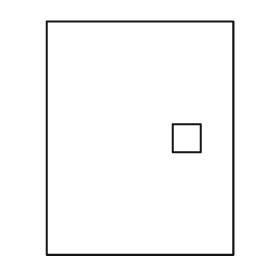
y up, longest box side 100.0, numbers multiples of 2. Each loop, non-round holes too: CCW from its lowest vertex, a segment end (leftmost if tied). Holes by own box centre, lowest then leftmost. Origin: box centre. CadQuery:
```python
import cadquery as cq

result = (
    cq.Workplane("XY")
    .moveTo(-40.0, -50.0)
    .lineTo(40.0, -50.0)
    .lineTo(40.0, 50.0)
    .lineTo(-40.0, 50.0)
    .close()
    .moveTo(14.0, -6.0)
    .lineTo(26.0, -6.0)
    .lineTo(26.0, 6.0)
    .lineTo(14.0, 6.0)
    .close()
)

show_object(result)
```